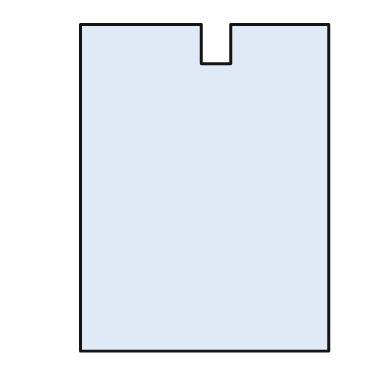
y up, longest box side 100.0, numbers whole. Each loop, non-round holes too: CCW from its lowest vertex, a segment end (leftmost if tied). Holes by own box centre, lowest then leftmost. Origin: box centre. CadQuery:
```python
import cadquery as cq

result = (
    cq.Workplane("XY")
    .moveTo(-38.0, -50.0)
    .lineTo(38.0, -50.0)
    .lineTo(38.0, 50.0)
    .lineTo(8.0, 50.0)
    .lineTo(8.0, 38.0)
    .lineTo(-1.0, 38.0)
    .lineTo(-1.0, 50.0)
    .lineTo(-38.0, 50.0)
    .close()
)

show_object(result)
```